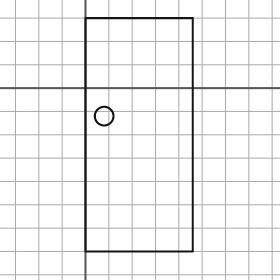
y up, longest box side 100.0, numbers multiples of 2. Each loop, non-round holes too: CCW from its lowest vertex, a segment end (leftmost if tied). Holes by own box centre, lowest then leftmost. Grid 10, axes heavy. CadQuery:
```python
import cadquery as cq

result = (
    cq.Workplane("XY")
    .moveTo(0.0, -70.0)
    .lineTo(46.0, -70.0)
    .lineTo(46.0, 30.0)
    .lineTo(0.0, 30.0)
    .close()
    .moveTo(8.0, -12.0)
    .circle(4.0)
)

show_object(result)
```